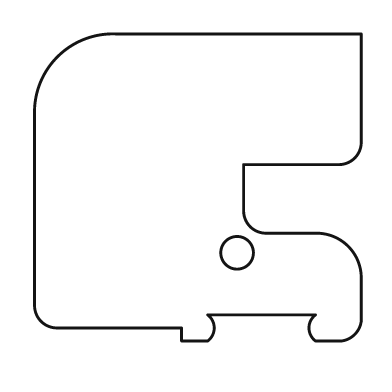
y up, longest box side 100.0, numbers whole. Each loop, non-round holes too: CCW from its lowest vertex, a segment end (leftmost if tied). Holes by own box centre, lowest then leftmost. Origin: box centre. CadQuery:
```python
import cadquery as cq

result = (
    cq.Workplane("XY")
    .moveTo(-5.0, -47.0)
    .lineTo(3.0, -47.0)
    .threePointArc((5.0, -43.0), (3.0, -39.0))
    .lineTo(36.0, -39.0)
    .threePointArc((34.0, -43.0), (36.0, -47.0))
    .lineTo(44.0, -47.0)
    .threePointArc((48.0, -45.0), (50.0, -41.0))
    .lineTo(50.0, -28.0)
    .threePointArc((46.0, -18.0), (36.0, -14.0))
    .lineTo(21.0, -14.0)
    .threePointArc((16.0, -12.0), (14.0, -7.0))
    .lineTo(14.0, 7.0)
    .lineTo(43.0, 7.0)
    .threePointArc((48.0, 9.0), (50.0, 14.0))
    .lineTo(50.0, 47.0)
    .lineTo(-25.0, 47.0)
    .threePointArc((-43.0, 40.0), (-50.0, 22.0))
    .lineTo(-50.0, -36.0)
    .threePointArc((-48.0, -41.0), (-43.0, -43.0))
    .lineTo(-5.0, -43.0)
    .close()
    .moveTo(12.0, -20.0)
    .circle(5.0)
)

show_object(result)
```